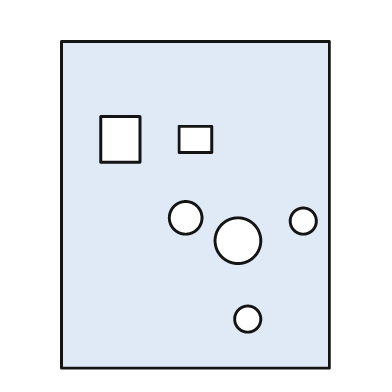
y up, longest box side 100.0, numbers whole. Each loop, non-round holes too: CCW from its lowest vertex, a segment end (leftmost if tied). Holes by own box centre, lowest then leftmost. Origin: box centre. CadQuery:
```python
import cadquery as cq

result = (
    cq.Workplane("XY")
    .moveTo(-41.0, -50.0)
    .lineTo(41.0, -50.0)
    .lineTo(41.0, 50.0)
    .lineTo(-41.0, 50.0)
    .close()
    .moveTo(16.0, -35.0)
    .circle(4.0)
    .moveTo(13.0, -11.0)
    .circle(7.0)
    .moveTo(33.0, -5.0)
    .circle(4.0)
    .moveTo(-3.0, -4.0)
    .circle(5.0)
    .moveTo(-29.0, 13.0)
    .lineTo(-17.0, 13.0)
    .lineTo(-17.0, 27.0)
    .lineTo(-29.0, 27.0)
    .close()
    .moveTo(-5.0, 16.0)
    .lineTo(5.0, 16.0)
    .lineTo(5.0, 24.0)
    .lineTo(-5.0, 24.0)
    .close()
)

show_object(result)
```